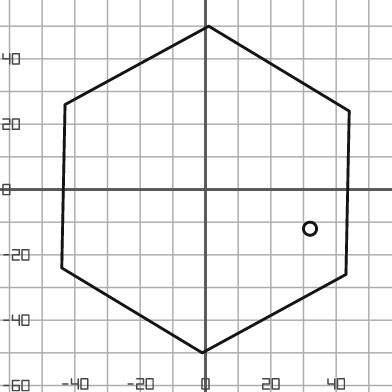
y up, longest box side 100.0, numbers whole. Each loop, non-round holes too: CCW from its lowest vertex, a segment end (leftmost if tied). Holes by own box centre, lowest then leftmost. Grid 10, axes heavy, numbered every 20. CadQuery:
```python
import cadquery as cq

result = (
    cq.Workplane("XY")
    .moveTo(-1.0, -50.0)
    .lineTo(43.0, -26.0)
    .lineTo(44.0, 24.0)
    .lineTo(1.0, 50.0)
    .lineTo(-43.0, 26.0)
    .lineTo(-44.0, -24.0)
    .close()
    .moveTo(32.0, -12.0)
    .circle(2.0)
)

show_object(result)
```